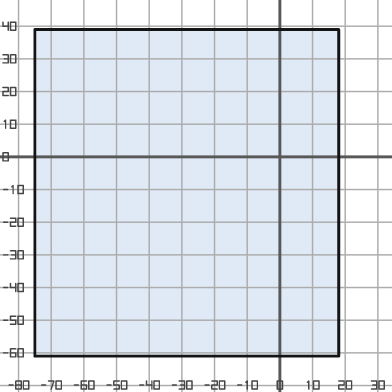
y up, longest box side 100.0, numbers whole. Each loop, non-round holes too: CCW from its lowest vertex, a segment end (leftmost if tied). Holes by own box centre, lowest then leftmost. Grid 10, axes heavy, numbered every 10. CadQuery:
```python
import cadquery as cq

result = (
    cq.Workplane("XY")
    .moveTo(-75.0, -61.0)
    .lineTo(18.0, -61.0)
    .lineTo(18.0, 39.0)
    .lineTo(-75.0, 39.0)
    .close()
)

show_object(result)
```